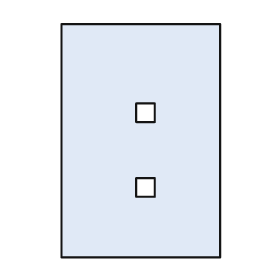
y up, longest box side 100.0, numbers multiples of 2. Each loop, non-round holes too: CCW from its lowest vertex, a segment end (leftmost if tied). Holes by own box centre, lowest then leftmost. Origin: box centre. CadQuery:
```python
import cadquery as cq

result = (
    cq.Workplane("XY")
    .moveTo(-34.0, -50.0)
    .lineTo(34.0, -50.0)
    .lineTo(34.0, 50.0)
    .lineTo(-34.0, 50.0)
    .close()
    .moveTo(-2.0, -24.0)
    .lineTo(6.0, -24.0)
    .lineTo(6.0, -16.0)
    .lineTo(-2.0, -16.0)
    .close()
    .moveTo(-2.0, 8.0)
    .lineTo(6.0, 8.0)
    .lineTo(6.0, 16.0)
    .lineTo(-2.0, 16.0)
    .close()
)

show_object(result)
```